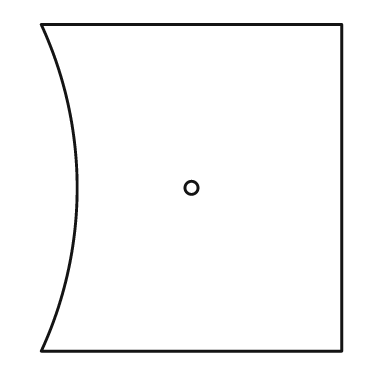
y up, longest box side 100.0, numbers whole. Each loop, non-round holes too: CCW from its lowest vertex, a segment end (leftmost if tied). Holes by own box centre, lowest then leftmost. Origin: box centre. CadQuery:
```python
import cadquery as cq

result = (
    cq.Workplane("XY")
    .moveTo(-46.0, -50.0)
    .lineTo(46.0, -50.0)
    .lineTo(46.0, 50.0)
    .lineTo(-46.0, 50.0)
    .threePointArc((-35.0, 0.0), (-46.0, -50.0))
    .close()
    .moveTo(0.0, 0.0)
    .circle(2.0)
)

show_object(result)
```